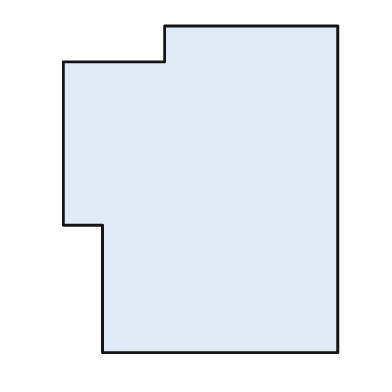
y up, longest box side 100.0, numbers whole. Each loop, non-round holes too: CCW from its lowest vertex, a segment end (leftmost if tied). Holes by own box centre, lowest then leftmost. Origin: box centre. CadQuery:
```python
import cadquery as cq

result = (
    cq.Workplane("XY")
    .moveTo(-30.0, -50.0)
    .lineTo(42.0, -50.0)
    .lineTo(42.0, 50.0)
    .lineTo(-11.0, 50.0)
    .lineTo(-11.0, 39.0)
    .lineTo(-42.0, 39.0)
    .lineTo(-42.0, -11.0)
    .lineTo(-30.0, -11.0)
    .close()
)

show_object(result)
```